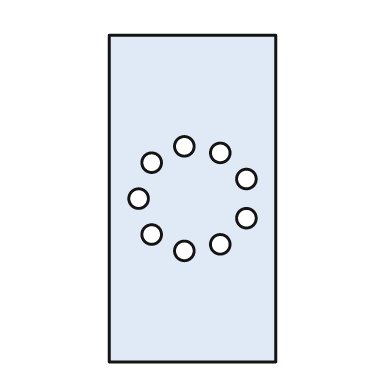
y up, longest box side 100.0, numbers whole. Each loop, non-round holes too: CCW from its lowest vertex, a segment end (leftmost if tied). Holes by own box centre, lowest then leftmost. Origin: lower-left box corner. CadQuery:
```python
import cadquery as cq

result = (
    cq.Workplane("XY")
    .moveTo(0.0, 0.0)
    .lineTo(51.0, 0.0)
    .lineTo(51.0, 100.0)
    .lineTo(0.0, 100.0)
    .close()
    .moveTo(23.0, 34.0)
    .circle(3.0)
    .moveTo(34.0, 36.0)
    .circle(3.0)
    .moveTo(13.0, 39.0)
    .circle(3.0)
    .moveTo(42.0, 44.0)
    .circle(3.0)
    .moveTo(9.0, 50.0)
    .circle(3.0)
    .moveTo(42.0, 56.0)
    .circle(3.0)
    .moveTo(13.0, 61.0)
    .circle(3.0)
    .moveTo(34.0, 64.0)
    .circle(3.0)
    .moveTo(23.0, 66.0)
    .circle(3.0)
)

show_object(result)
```